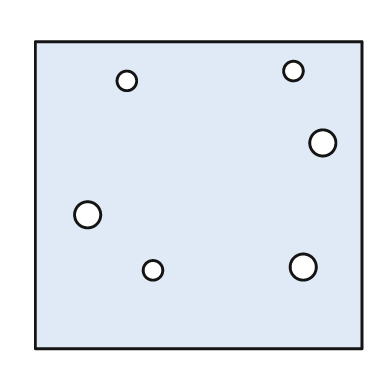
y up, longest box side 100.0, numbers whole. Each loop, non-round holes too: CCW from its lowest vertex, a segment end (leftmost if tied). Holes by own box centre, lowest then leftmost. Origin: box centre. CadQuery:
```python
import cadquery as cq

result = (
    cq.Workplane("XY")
    .moveTo(-50.0, -47.0)
    .lineTo(50.0, -47.0)
    .lineTo(50.0, 47.0)
    .lineTo(-50.0, 47.0)
    .close()
    .moveTo(-14.0, -23.0)
    .circle(3.0)
    .moveTo(32.0, -22.0)
    .circle(4.0)
    .moveTo(-34.0, -6.0)
    .circle(4.0)
    .moveTo(38.0, 16.0)
    .circle(4.0)
    .moveTo(-22.0, 35.0)
    .circle(3.0)
    .moveTo(29.0, 38.0)
    .circle(3.0)
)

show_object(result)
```